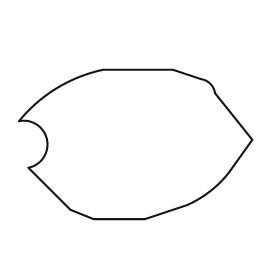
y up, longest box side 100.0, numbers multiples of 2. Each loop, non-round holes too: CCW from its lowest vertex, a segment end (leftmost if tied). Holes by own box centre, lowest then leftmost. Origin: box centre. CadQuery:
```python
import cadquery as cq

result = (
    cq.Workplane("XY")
    .moveTo(-18.0, -32.0)
    .lineTo(4.0, -32.0)
    .lineTo(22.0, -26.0)
    .threePointArc((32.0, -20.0), (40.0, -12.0))
    .lineTo(50.0, 2.0)
    .lineTo(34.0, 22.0)
    .threePointArc((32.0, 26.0), (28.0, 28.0))
    .lineTo(16.0, 32.0)
    .lineTo(-14.0, 32.0)
    .threePointArc((-34.0, 24.0), (-50.0, 10.0))
    .threePointArc((-38.0, 2.0), (-46.0, -10.0))
    .lineTo(-28.0, -28.0)
    .close()
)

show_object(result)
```